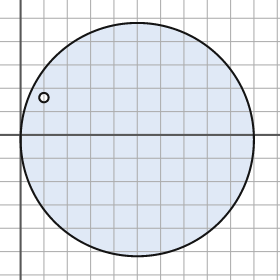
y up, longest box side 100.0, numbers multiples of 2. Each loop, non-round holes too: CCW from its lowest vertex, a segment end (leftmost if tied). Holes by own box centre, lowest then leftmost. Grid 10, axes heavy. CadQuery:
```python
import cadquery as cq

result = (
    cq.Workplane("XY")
    .moveTo(50.0, -2.0)
    .circle(50.0)
    .moveTo(10.0, 16.0)
    .circle(2.0)
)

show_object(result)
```